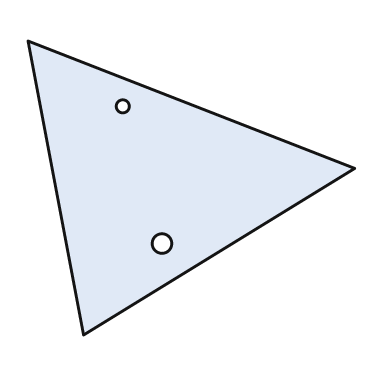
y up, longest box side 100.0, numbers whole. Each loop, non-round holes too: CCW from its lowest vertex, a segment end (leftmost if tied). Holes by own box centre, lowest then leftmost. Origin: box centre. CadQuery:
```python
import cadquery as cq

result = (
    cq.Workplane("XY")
    .moveTo(-33.0, -45.0)
    .lineTo(50.0, 6.0)
    .lineTo(-50.0, 45.0)
    .close()
    .moveTo(-9.0, -17.0)
    .circle(3.0)
    .moveTo(-21.0, 25.0)
    .circle(2.0)
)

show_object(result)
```